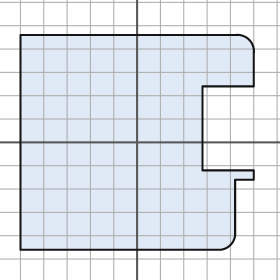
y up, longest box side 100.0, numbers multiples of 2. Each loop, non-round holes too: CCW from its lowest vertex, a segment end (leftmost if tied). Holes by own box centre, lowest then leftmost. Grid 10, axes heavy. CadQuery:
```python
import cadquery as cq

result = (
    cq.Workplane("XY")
    .moveTo(-50.0, -46.0)
    .lineTo(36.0, -46.0)
    .threePointArc((40.0, -44.0), (42.0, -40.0))
    .lineTo(42.0, -16.0)
    .lineTo(50.0, -16.0)
    .lineTo(50.0, -12.0)
    .lineTo(28.0, -12.0)
    .lineTo(28.0, 24.0)
    .lineTo(50.0, 24.0)
    .lineTo(50.0, 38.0)
    .threePointArc((48.0, 44.0), (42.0, 46.0))
    .lineTo(-50.0, 46.0)
    .close()
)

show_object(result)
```